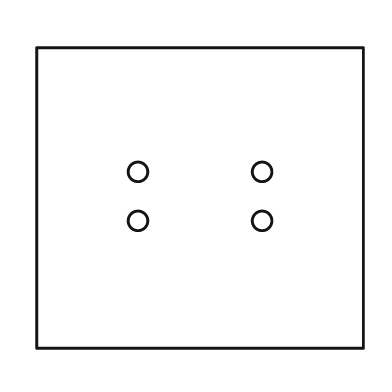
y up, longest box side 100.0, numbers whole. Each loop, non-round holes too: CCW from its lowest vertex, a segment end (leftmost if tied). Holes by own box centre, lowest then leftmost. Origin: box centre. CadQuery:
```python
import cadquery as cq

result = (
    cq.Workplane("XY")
    .moveTo(-50.0, -46.0)
    .lineTo(50.0, -46.0)
    .lineTo(50.0, 46.0)
    .lineTo(-50.0, 46.0)
    .close()
    .moveTo(-19.0, -7.0)
    .circle(3.0)
    .moveTo(19.0, -7.0)
    .circle(3.0)
    .moveTo(-19.0, 8.0)
    .circle(3.0)
    .moveTo(19.0, 8.0)
    .circle(3.0)
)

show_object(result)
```